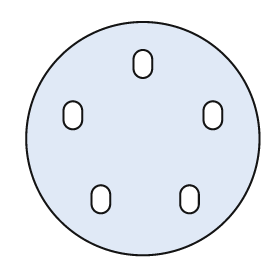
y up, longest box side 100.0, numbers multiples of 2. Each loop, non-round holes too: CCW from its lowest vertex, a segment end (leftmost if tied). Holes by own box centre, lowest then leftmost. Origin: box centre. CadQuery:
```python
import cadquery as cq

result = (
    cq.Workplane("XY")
    .moveTo(0.0, 0.0)
    .circle(50.0)
    .moveTo(-22.0, -28.0)
    .threePointArc((-18.0, -32.0), (-14.0, -28.0))
    .lineTo(-14.0, -24.0)
    .threePointArc((-18.0, -20.0), (-22.0, -24.0))
    .close()
    .moveTo(16.0, -28.0)
    .threePointArc((20.0, -32.0), (24.0, -28.0))
    .lineTo(24.0, -24.0)
    .threePointArc((20.0, -20.0), (16.0, -24.0))
    .close()
    .moveTo(-34.0, 8.0)
    .threePointArc((-30.0, 4.0), (-26.0, 8.0))
    .lineTo(-26.0, 12.0)
    .threePointArc((-30.0, 16.0), (-34.0, 12.0))
    .close()
    .moveTo(26.0, 8.0)
    .threePointArc((30.0, 4.0), (34.0, 8.0))
    .lineTo(34.0, 12.0)
    .threePointArc((30.0, 16.0), (26.0, 12.0))
    .close()
    .moveTo(-4.0, 30.0)
    .threePointArc((0.0, 26.0), (4.0, 30.0))
    .lineTo(4.0, 34.0)
    .threePointArc((0.0, 38.0), (-4.0, 34.0))
    .close()
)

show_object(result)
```